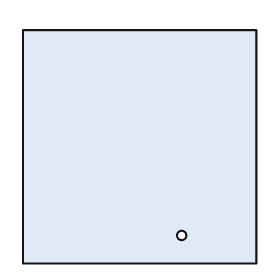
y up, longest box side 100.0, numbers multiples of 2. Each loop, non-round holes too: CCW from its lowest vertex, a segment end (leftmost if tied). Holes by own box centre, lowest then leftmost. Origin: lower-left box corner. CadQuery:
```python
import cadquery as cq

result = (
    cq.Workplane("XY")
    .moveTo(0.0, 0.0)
    .lineTo(100.0, 0.0)
    .lineTo(100.0, 100.0)
    .lineTo(0.0, 100.0)
    .close()
    .moveTo(68.0, 12.0)
    .circle(2.0)
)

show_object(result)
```